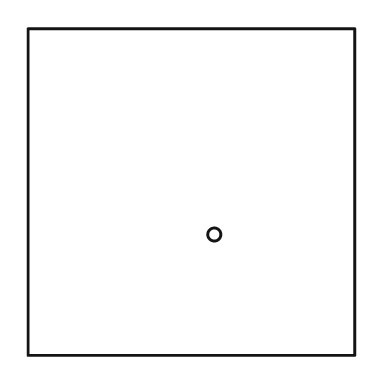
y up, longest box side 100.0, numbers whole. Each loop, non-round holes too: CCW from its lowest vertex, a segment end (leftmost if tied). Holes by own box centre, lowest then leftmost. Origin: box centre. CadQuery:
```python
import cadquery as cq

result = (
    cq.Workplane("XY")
    .moveTo(-50.0, -50.0)
    .lineTo(50.0, -50.0)
    .lineTo(50.0, 50.0)
    .lineTo(-50.0, 50.0)
    .close()
    .moveTo(7.0, -13.0)
    .circle(2.0)
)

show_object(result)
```